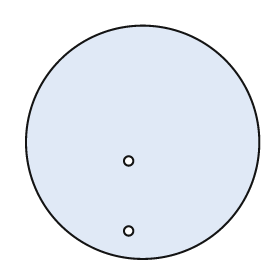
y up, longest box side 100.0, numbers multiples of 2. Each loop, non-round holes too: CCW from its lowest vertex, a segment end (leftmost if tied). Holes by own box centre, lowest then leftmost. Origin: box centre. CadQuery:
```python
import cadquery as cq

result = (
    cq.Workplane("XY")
    .moveTo(0.0, 0.0)
    .circle(50.0)
    .moveTo(-6.0, -38.0)
    .circle(2.0)
    .moveTo(-6.0, -8.0)
    .circle(2.0)
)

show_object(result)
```